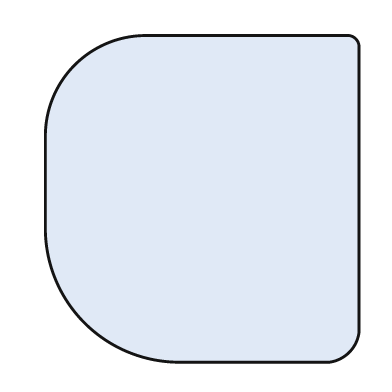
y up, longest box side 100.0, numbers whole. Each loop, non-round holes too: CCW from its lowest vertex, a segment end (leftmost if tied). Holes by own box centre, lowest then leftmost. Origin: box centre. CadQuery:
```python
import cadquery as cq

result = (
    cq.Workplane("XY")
    .moveTo(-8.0, -50.0)
    .lineTo(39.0, -50.0)
    .threePointArc((45.0, -47.0), (48.0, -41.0))
    .lineTo(48.0, 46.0)
    .threePointArc((47.0, 49.0), (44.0, 50.0))
    .lineTo(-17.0, 50.0)
    .threePointArc((-39.0, 41.0), (-48.0, 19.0))
    .lineTo(-48.0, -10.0)
    .threePointArc((-36.0, -38.0), (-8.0, -50.0))
    .close()
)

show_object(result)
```